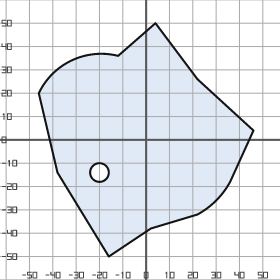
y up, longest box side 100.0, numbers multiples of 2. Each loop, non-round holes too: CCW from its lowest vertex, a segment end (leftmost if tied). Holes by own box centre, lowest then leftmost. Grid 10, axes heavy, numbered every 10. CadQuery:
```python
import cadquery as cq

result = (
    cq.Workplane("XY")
    .moveTo(-16.0, -50.0)
    .lineTo(2.0, -38.0)
    .lineTo(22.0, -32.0)
    .threePointArc((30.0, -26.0), (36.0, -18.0))
    .lineTo(46.0, 4.0)
    .lineTo(22.0, 26.0)
    .lineTo(4.0, 50.0)
    .lineTo(-12.0, 36.0)
    .threePointArc((-32.0, 34.0), (-46.0, 20.0))
    .lineTo(-38.0, -14.0)
    .close()
    .moveTo(-20.0, -14.0)
    .circle(4.0)
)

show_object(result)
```